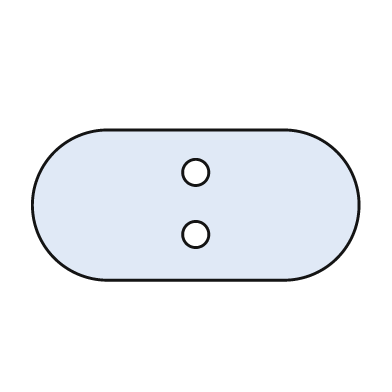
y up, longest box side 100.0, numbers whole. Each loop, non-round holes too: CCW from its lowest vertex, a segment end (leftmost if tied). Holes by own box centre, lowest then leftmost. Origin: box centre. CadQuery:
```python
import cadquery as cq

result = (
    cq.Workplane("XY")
    .moveTo(-27.0, -23.0)
    .lineTo(27.0, -23.0)
    .threePointArc((50.0, 0.0), (27.0, 23.0))
    .lineTo(-27.0, 23.0)
    .threePointArc((-50.0, 0.0), (-27.0, -23.0))
    .close()
    .moveTo(0.0, -9.0)
    .circle(4.0)
    .moveTo(0.0, 10.0)
    .circle(4.0)
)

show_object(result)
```